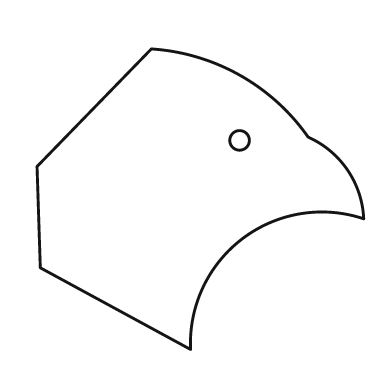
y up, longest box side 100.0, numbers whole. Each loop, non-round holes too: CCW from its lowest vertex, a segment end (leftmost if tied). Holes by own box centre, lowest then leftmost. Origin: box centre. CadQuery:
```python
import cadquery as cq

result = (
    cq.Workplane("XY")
    .moveTo(-3.0, -46.0)
    .threePointArc((13.0, -12.0), (50.0, -6.0))
    .threePointArc((45.0, 9.0), (33.0, 19.0))
    .threePointArc((12.0, 38.0), (-15.0, 46.0))
    .lineTo(-50.0, 10.0)
    .lineTo(-49.0, -21.0)
    .close()
    .moveTo(12.0, 18.0)
    .circle(3.0)
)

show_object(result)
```